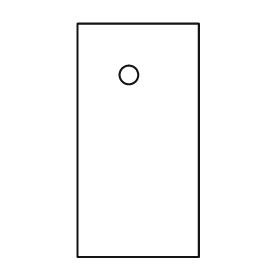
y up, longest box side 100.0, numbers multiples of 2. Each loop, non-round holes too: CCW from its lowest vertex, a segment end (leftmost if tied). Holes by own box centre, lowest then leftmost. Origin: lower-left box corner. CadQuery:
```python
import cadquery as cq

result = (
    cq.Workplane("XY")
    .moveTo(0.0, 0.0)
    .lineTo(52.0, 0.0)
    .lineTo(52.0, 100.0)
    .lineTo(0.0, 100.0)
    .close()
    .moveTo(22.0, 78.0)
    .circle(4.0)
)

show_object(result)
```